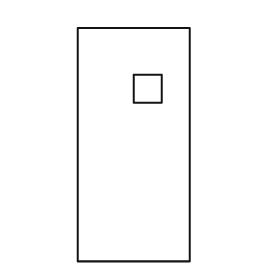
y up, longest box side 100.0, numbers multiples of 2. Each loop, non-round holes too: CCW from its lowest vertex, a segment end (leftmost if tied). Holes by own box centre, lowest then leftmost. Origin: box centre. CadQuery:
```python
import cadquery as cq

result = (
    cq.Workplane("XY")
    .moveTo(-24.0, -50.0)
    .lineTo(24.0, -50.0)
    .lineTo(24.0, 50.0)
    .lineTo(-24.0, 50.0)
    .close()
    .moveTo(0.0, 18.0)
    .lineTo(12.0, 18.0)
    .lineTo(12.0, 30.0)
    .lineTo(0.0, 30.0)
    .close()
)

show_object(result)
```